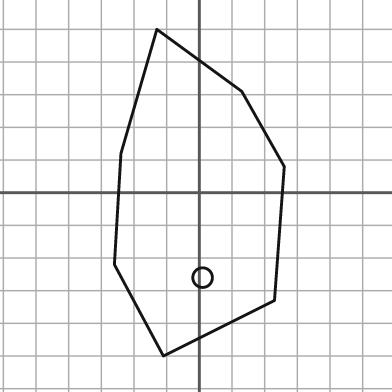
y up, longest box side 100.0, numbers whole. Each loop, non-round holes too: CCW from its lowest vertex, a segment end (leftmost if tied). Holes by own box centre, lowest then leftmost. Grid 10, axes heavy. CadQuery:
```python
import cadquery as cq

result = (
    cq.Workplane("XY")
    .moveTo(-11.0, -50.0)
    .lineTo(23.0, -33.0)
    .lineTo(26.0, 8.0)
    .lineTo(13.0, 31.0)
    .lineTo(-13.0, 50.0)
    .lineTo(-24.0, 12.0)
    .lineTo(-26.0, -22.0)
    .close()
    .moveTo(1.0, -26.0)
    .circle(3.0)
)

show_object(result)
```